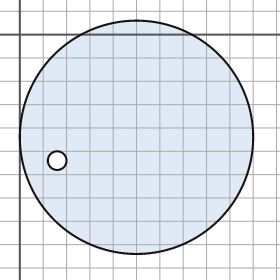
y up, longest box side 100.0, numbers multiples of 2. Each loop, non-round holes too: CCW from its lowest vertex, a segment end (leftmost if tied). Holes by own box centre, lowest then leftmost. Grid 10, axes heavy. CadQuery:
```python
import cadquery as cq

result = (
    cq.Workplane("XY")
    .moveTo(50.0, -44.0)
    .circle(50.0)
    .moveTo(16.0, -54.0)
    .circle(4.0)
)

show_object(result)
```